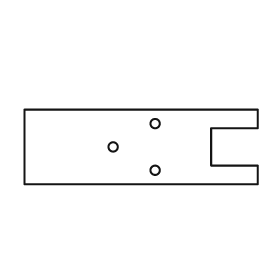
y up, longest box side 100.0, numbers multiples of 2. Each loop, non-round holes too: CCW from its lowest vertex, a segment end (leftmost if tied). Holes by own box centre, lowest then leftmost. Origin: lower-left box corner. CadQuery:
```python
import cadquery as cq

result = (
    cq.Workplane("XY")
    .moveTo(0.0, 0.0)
    .lineTo(100.0, 0.0)
    .lineTo(100.0, 8.0)
    .lineTo(80.0, 8.0)
    .lineTo(80.0, 24.0)
    .lineTo(100.0, 24.0)
    .lineTo(100.0, 32.0)
    .lineTo(0.0, 32.0)
    .close()
    .moveTo(56.0, 6.0)
    .circle(2.0)
    .moveTo(38.0, 16.0)
    .circle(2.0)
    .moveTo(56.0, 26.0)
    .circle(2.0)
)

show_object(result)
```